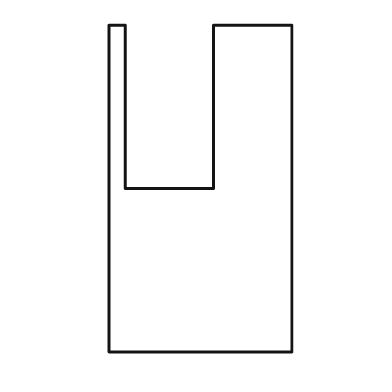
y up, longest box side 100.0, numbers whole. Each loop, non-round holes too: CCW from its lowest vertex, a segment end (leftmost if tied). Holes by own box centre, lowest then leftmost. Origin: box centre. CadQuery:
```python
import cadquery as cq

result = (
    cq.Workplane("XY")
    .moveTo(-28.0, -50.0)
    .lineTo(28.0, -50.0)
    .lineTo(28.0, 50.0)
    .lineTo(4.0, 50.0)
    .lineTo(4.0, 0.0)
    .lineTo(-23.0, 0.0)
    .lineTo(-23.0, 50.0)
    .lineTo(-28.0, 50.0)
    .close()
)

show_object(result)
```